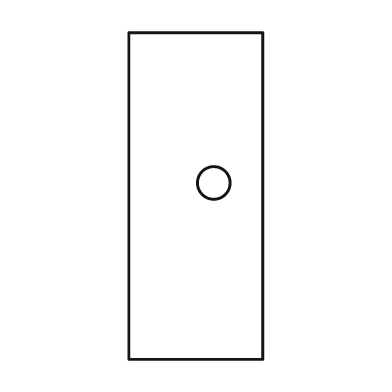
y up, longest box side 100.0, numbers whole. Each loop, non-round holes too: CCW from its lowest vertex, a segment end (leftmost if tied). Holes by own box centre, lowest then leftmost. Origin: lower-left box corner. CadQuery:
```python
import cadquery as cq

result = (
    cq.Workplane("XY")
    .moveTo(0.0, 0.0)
    .lineTo(41.0, 0.0)
    .lineTo(41.0, 100.0)
    .lineTo(0.0, 100.0)
    .close()
    .moveTo(26.0, 54.0)
    .circle(5.0)
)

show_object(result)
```